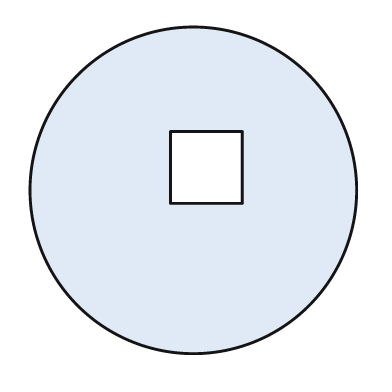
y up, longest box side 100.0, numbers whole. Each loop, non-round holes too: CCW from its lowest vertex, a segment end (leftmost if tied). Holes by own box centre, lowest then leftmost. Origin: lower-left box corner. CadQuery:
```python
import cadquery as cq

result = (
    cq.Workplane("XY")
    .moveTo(50.0, 50.0)
    .circle(50.0)
    .moveTo(43.0, 46.0)
    .lineTo(65.0, 46.0)
    .lineTo(65.0, 68.0)
    .lineTo(43.0, 68.0)
    .close()
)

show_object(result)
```